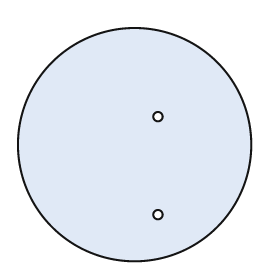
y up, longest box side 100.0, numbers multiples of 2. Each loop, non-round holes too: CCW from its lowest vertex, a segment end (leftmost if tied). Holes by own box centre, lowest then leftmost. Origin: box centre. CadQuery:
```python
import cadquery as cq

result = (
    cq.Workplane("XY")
    .moveTo(0.0, 0.0)
    .circle(50.0)
    .moveTo(10.0, -30.0)
    .circle(2.0)
    .moveTo(10.0, 12.0)
    .circle(2.0)
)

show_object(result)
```